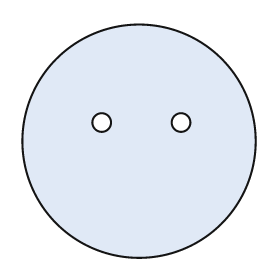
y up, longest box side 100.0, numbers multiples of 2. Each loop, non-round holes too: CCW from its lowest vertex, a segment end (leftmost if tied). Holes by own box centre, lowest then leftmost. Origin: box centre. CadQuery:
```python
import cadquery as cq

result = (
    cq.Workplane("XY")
    .moveTo(0.0, 0.0)
    .circle(50.0)
    .moveTo(-16.0, 8.0)
    .circle(4.0)
    .moveTo(18.0, 8.0)
    .circle(4.0)
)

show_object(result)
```